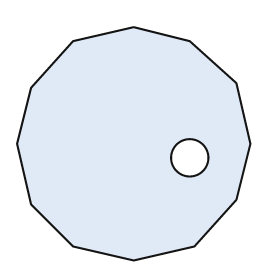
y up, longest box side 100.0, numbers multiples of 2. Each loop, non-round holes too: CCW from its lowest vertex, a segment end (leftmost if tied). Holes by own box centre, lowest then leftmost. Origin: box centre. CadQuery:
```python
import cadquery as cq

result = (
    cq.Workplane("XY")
    .moveTo(0.0, -50.0)
    .lineTo(26.0, -44.0)
    .lineTo(44.0, -24.0)
    .lineTo(50.0, 0.0)
    .lineTo(44.0, 26.0)
    .lineTo(24.0, 44.0)
    .lineTo(0.0, 50.0)
    .lineTo(-26.0, 44.0)
    .lineTo(-44.0, 24.0)
    .lineTo(-50.0, 0.0)
    .lineTo(-44.0, -26.0)
    .lineTo(-26.0, -44.0)
    .close()
    .moveTo(24.0, -6.0)
    .circle(8.0)
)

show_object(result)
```